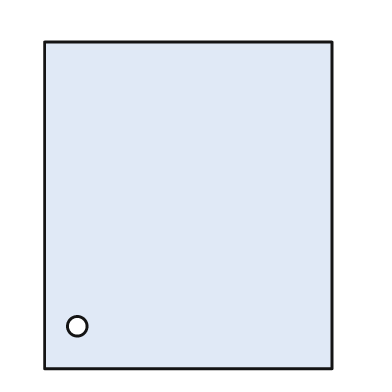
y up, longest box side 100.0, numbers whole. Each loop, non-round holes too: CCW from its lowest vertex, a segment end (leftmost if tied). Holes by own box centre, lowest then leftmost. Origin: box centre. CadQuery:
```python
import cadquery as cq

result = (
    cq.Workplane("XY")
    .moveTo(-44.0, -50.0)
    .lineTo(44.0, -50.0)
    .lineTo(44.0, 50.0)
    .lineTo(-44.0, 50.0)
    .close()
    .moveTo(-34.0, -37.0)
    .circle(3.0)
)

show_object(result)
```